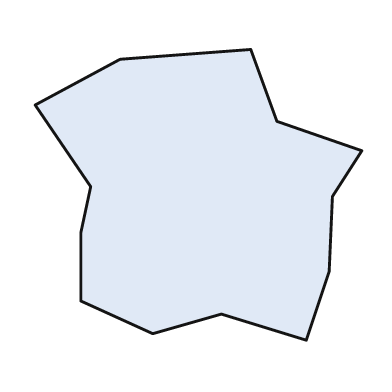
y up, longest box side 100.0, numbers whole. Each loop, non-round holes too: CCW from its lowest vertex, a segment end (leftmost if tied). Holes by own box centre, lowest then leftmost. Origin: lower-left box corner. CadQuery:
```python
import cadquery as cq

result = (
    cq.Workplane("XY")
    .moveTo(83.0, 0.0)
    .lineTo(90.0, 21.0)
    .lineTo(91.0, 44.0)
    .lineTo(100.0, 58.0)
    .lineTo(74.0, 67.0)
    .lineTo(66.0, 89.0)
    .lineTo(26.0, 86.0)
    .lineTo(0.0, 72.0)
    .lineTo(17.0, 47.0)
    .lineTo(14.0, 33.0)
    .lineTo(14.0, 12.0)
    .lineTo(36.0, 2.0)
    .lineTo(57.0, 8.0)
    .close()
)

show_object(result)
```